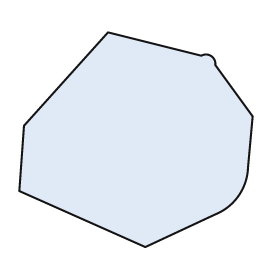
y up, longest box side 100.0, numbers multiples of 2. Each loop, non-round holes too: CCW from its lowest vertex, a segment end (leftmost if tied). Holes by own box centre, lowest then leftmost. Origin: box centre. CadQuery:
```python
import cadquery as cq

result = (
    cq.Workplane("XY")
    .moveTo(4.0, -46.0)
    .lineTo(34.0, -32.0)
    .threePointArc((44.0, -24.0), (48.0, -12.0))
    .lineTo(50.0, 10.0)
    .lineTo(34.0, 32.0)
    .threePointArc((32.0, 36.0), (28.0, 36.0))
    .lineTo(-12.0, 46.0)
    .lineTo(-48.0, 6.0)
    .lineTo(-50.0, -22.0)
    .close()
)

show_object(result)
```